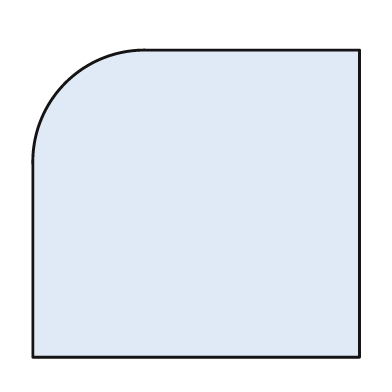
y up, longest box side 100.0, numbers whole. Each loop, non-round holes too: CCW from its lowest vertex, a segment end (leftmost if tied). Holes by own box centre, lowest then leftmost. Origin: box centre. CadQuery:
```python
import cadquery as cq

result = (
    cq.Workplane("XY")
    .moveTo(-50.0, -47.0)
    .lineTo(50.0, -47.0)
    .lineTo(50.0, 47.0)
    .lineTo(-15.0, 47.0)
    .threePointArc((-40.0, 37.0), (-50.0, 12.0))
    .close()
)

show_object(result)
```